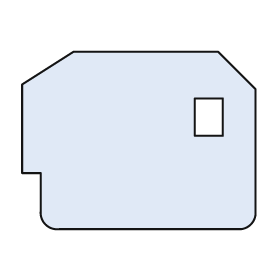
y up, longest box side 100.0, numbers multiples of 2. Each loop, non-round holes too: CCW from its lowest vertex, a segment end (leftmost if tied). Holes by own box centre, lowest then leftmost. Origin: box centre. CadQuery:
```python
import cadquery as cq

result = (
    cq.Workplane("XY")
    .moveTo(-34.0, -38.0)
    .lineTo(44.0, -38.0)
    .threePointArc((48.0, -36.0), (50.0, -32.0))
    .lineTo(50.0, 22.0)
    .lineTo(34.0, 38.0)
    .lineTo(-28.0, 38.0)
    .lineTo(-50.0, 24.0)
    .lineTo(-50.0, -14.0)
    .lineTo(-42.0, -14.0)
    .lineTo(-42.0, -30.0)
    .threePointArc((-40.0, -36.0), (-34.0, -38.0))
    .close()
    .moveTo(24.0, 2.0)
    .lineTo(36.0, 2.0)
    .lineTo(36.0, 18.0)
    .lineTo(24.0, 18.0)
    .close()
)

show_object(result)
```